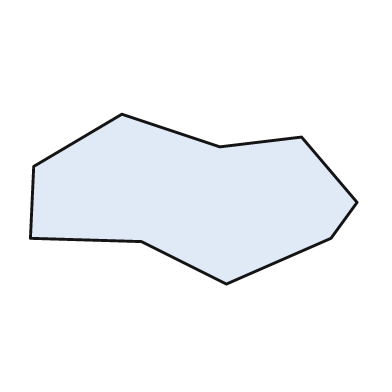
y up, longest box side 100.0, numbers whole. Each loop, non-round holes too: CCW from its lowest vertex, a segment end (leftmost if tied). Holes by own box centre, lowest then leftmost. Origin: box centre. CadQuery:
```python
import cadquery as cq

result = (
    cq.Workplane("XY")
    .moveTo(10.0, -26.0)
    .lineTo(42.0, -12.0)
    .lineTo(50.0, -1.0)
    .lineTo(33.0, 19.0)
    .lineTo(8.0, 16.0)
    .lineTo(-22.0, 26.0)
    .lineTo(-49.0, 10.0)
    .lineTo(-50.0, -12.0)
    .lineTo(-16.0, -13.0)
    .close()
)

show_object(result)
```